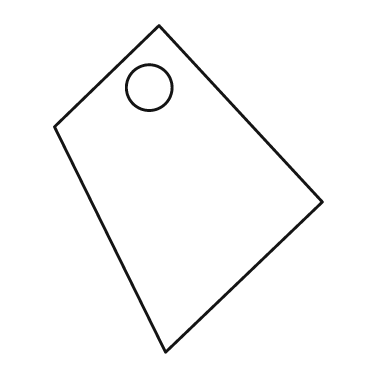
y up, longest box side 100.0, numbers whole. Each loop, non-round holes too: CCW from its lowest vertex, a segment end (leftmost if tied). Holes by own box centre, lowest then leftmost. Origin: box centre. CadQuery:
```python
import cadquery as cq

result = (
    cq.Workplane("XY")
    .moveTo(-7.0, -50.0)
    .lineTo(41.0, -4.0)
    .lineTo(-9.0, 50.0)
    .lineTo(-41.0, 19.0)
    .close()
    .moveTo(-12.0, 31.0)
    .circle(7.0)
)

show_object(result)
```